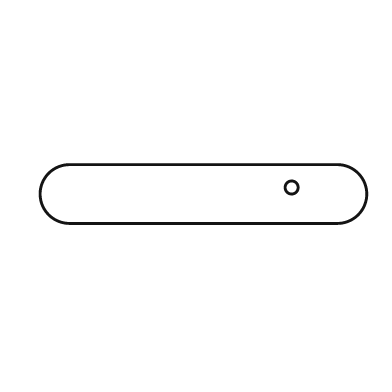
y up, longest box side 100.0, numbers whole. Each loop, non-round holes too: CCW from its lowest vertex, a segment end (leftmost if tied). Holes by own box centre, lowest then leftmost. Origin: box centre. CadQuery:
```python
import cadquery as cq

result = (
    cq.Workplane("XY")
    .moveTo(-41.0, -9.0)
    .lineTo(41.0, -9.0)
    .threePointArc((50.0, 0.0), (41.0, 9.0))
    .lineTo(-41.0, 9.0)
    .threePointArc((-50.0, 0.0), (-41.0, -9.0))
    .close()
    .moveTo(27.0, 2.0)
    .circle(2.0)
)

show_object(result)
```